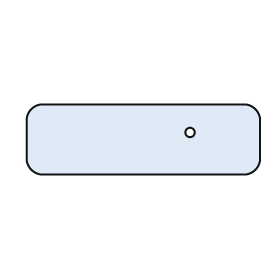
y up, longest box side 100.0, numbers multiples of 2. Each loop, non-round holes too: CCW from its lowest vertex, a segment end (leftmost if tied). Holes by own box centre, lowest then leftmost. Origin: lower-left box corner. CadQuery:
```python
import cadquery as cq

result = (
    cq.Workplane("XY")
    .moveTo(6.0, 0.0)
    .lineTo(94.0, 0.0)
    .threePointArc((98.0, 2.0), (100.0, 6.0))
    .lineTo(100.0, 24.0)
    .threePointArc((98.0, 28.0), (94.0, 30.0))
    .lineTo(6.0, 30.0)
    .threePointArc((2.0, 28.0), (0.0, 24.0))
    .lineTo(0.0, 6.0)
    .threePointArc((2.0, 2.0), (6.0, 0.0))
    .close()
    .moveTo(70.0, 18.0)
    .circle(2.0)
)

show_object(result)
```